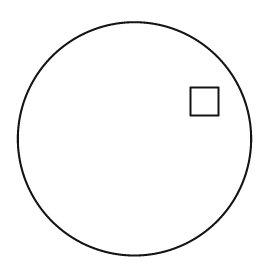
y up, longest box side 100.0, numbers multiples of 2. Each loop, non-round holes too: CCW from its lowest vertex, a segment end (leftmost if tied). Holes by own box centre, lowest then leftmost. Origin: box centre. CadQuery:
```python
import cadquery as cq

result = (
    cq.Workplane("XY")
    .moveTo(0.0, 0.0)
    .circle(50.0)
    .moveTo(24.0, 10.0)
    .lineTo(36.0, 10.0)
    .lineTo(36.0, 22.0)
    .lineTo(24.0, 22.0)
    .close()
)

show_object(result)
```